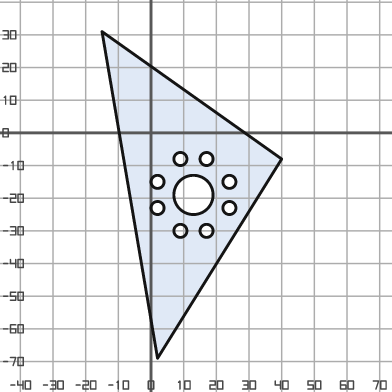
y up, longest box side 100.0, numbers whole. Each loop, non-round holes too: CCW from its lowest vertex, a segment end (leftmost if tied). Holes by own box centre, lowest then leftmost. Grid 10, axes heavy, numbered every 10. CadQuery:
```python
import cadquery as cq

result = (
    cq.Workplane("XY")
    .moveTo(2.0, -69.0)
    .lineTo(40.0, -8.0)
    .lineTo(-15.0, 31.0)
    .close()
    .moveTo(9.0, -30.0)
    .circle(2.0)
    .moveTo(17.0, -30.0)
    .circle(2.0)
    .moveTo(2.0, -23.0)
    .circle(2.0)
    .moveTo(24.0, -23.0)
    .circle(2.0)
    .moveTo(13.0, -19.0)
    .circle(6.0)
    .moveTo(2.0, -15.0)
    .circle(2.0)
    .moveTo(24.0, -15.0)
    .circle(2.0)
    .moveTo(9.0, -8.0)
    .circle(2.0)
    .moveTo(17.0, -8.0)
    .circle(2.0)
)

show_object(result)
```